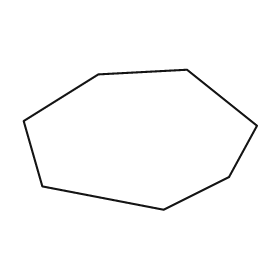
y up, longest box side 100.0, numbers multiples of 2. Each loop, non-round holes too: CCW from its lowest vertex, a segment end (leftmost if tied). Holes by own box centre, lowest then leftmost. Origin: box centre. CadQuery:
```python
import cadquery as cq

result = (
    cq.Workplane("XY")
    .moveTo(10.0, -30.0)
    .lineTo(38.0, -16.0)
    .lineTo(50.0, 6.0)
    .lineTo(20.0, 30.0)
    .lineTo(-18.0, 28.0)
    .lineTo(-50.0, 8.0)
    .lineTo(-42.0, -20.0)
    .close()
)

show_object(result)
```